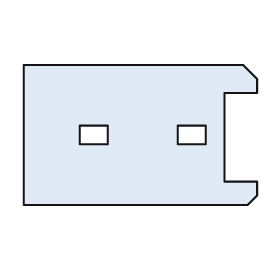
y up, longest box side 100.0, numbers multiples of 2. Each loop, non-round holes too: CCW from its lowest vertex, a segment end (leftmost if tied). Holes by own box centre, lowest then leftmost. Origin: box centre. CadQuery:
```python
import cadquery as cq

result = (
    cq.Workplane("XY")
    .moveTo(-50.0, -30.0)
    .lineTo(46.0, -30.0)
    .lineTo(50.0, -26.0)
    .lineTo(50.0, -20.0)
    .lineTo(36.0, -20.0)
    .lineTo(36.0, 18.0)
    .lineTo(50.0, 18.0)
    .lineTo(50.0, 24.0)
    .lineTo(44.0, 30.0)
    .lineTo(-50.0, 30.0)
    .close()
    .moveTo(-26.0, -4.0)
    .lineTo(-14.0, -4.0)
    .lineTo(-14.0, 4.0)
    .lineTo(-26.0, 4.0)
    .close()
    .moveTo(16.0, -4.0)
    .lineTo(28.0, -4.0)
    .lineTo(28.0, 4.0)
    .lineTo(16.0, 4.0)
    .close()
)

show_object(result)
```